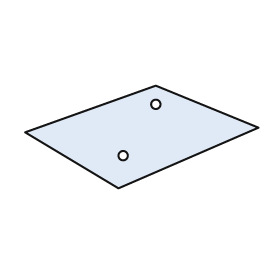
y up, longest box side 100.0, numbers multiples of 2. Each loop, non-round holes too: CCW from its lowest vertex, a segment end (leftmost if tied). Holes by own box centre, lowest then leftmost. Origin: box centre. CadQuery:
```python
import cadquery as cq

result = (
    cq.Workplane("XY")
    .moveTo(-10.0, -22.0)
    .lineTo(50.0, 4.0)
    .lineTo(6.0, 22.0)
    .lineTo(-50.0, 2.0)
    .close()
    .moveTo(-8.0, -8.0)
    .circle(2.0)
    .moveTo(6.0, 14.0)
    .circle(2.0)
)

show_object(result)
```